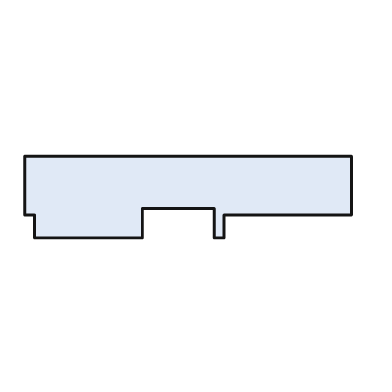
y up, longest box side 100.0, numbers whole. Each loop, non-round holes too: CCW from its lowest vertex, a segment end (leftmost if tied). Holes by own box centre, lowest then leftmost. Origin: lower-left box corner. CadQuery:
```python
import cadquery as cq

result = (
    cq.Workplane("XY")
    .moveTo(3.0, 0.0)
    .lineTo(36.0, 0.0)
    .lineTo(36.0, 9.0)
    .lineTo(58.0, 9.0)
    .lineTo(58.0, 0.0)
    .lineTo(61.0, 0.0)
    .lineTo(61.0, 7.0)
    .lineTo(100.0, 7.0)
    .lineTo(100.0, 25.0)
    .lineTo(0.0, 25.0)
    .lineTo(0.0, 7.0)
    .lineTo(3.0, 7.0)
    .close()
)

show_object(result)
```